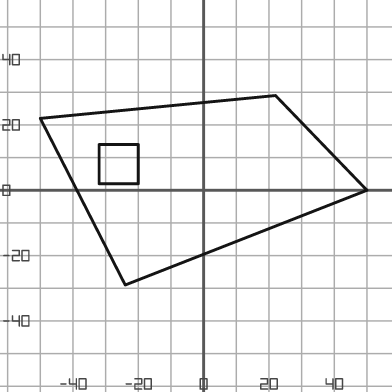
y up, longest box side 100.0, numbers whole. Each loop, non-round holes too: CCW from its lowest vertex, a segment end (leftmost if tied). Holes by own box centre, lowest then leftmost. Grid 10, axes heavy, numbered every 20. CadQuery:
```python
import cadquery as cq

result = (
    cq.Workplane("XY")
    .moveTo(-24.0, -29.0)
    .lineTo(50.0, 0.0)
    .lineTo(22.0, 29.0)
    .lineTo(-50.0, 22.0)
    .close()
    .moveTo(-32.0, 2.0)
    .lineTo(-20.0, 2.0)
    .lineTo(-20.0, 14.0)
    .lineTo(-32.0, 14.0)
    .close()
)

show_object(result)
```